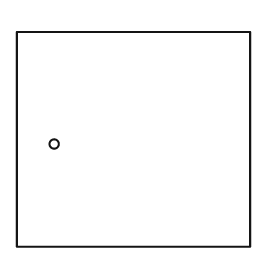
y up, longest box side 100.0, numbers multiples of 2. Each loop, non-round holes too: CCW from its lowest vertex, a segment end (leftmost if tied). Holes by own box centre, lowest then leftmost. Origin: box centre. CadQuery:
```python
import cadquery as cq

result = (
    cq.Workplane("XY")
    .moveTo(-50.0, -46.0)
    .lineTo(50.0, -46.0)
    .lineTo(50.0, 46.0)
    .lineTo(-50.0, 46.0)
    .close()
    .moveTo(-34.0, -2.0)
    .circle(2.0)
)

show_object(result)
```